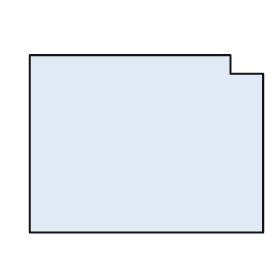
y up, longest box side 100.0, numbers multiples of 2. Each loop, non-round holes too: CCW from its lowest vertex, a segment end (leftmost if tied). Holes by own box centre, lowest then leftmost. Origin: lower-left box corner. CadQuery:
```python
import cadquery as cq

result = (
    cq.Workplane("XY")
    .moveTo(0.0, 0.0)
    .lineTo(100.0, 0.0)
    .lineTo(100.0, 68.0)
    .lineTo(86.0, 68.0)
    .lineTo(86.0, 76.0)
    .lineTo(0.0, 76.0)
    .close()
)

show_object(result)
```